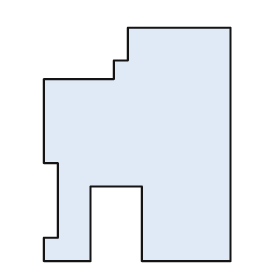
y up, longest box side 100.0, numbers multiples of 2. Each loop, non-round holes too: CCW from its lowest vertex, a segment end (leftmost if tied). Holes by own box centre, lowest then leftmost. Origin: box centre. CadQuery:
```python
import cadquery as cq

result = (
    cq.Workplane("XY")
    .moveTo(-40.0, -50.0)
    .lineTo(-20.0, -50.0)
    .lineTo(-20.0, -18.0)
    .lineTo(2.0, -18.0)
    .lineTo(2.0, -50.0)
    .lineTo(40.0, -50.0)
    .lineTo(40.0, 50.0)
    .lineTo(-4.0, 50.0)
    .lineTo(-4.0, 36.0)
    .lineTo(-10.0, 36.0)
    .lineTo(-10.0, 28.0)
    .lineTo(-40.0, 28.0)
    .lineTo(-40.0, -8.0)
    .lineTo(-34.0, -8.0)
    .lineTo(-34.0, -40.0)
    .lineTo(-40.0, -40.0)
    .close()
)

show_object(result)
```